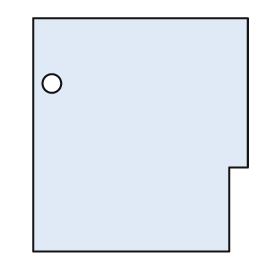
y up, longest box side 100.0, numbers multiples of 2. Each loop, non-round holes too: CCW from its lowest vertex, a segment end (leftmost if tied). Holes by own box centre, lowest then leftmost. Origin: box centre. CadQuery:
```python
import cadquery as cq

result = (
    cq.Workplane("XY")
    .moveTo(-46.0, -50.0)
    .lineTo(38.0, -50.0)
    .lineTo(38.0, -14.0)
    .lineTo(46.0, -14.0)
    .lineTo(46.0, 50.0)
    .lineTo(-46.0, 50.0)
    .close()
    .moveTo(-38.0, 22.0)
    .circle(4.0)
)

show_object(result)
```